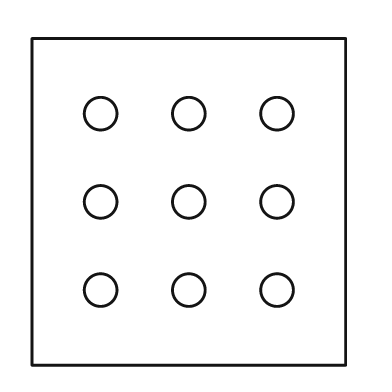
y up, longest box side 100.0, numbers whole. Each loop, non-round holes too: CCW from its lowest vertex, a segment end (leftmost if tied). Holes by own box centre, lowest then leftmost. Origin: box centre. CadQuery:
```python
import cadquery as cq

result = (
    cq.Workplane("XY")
    .moveTo(-48.0, -50.0)
    .lineTo(48.0, -50.0)
    .lineTo(48.0, 50.0)
    .lineTo(-48.0, 50.0)
    .close()
    .moveTo(-27.0, -27.0)
    .circle(5.0)
    .moveTo(0.0, -27.0)
    .circle(5.0)
    .moveTo(27.0, -27.0)
    .circle(5.0)
    .moveTo(-27.0, 0.0)
    .circle(5.0)
    .moveTo(0.0, 0.0)
    .circle(5.0)
    .moveTo(27.0, 0.0)
    .circle(5.0)
    .moveTo(-27.0, 27.0)
    .circle(5.0)
    .moveTo(0.0, 27.0)
    .circle(5.0)
    .moveTo(27.0, 27.0)
    .circle(5.0)
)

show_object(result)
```